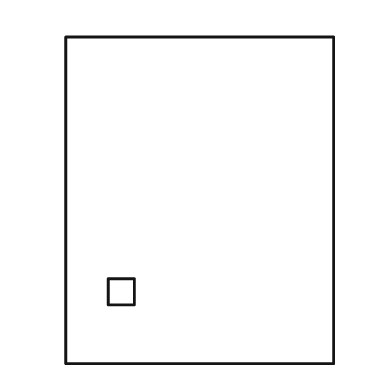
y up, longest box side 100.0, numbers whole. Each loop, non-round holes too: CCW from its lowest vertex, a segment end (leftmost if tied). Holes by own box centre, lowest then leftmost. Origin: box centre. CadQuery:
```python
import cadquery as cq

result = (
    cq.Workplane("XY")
    .moveTo(-41.0, -50.0)
    .lineTo(41.0, -50.0)
    .lineTo(41.0, 50.0)
    .lineTo(-41.0, 50.0)
    .close()
    .moveTo(-28.0, -32.0)
    .lineTo(-20.0, -32.0)
    .lineTo(-20.0, -24.0)
    .lineTo(-28.0, -24.0)
    .close()
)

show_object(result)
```